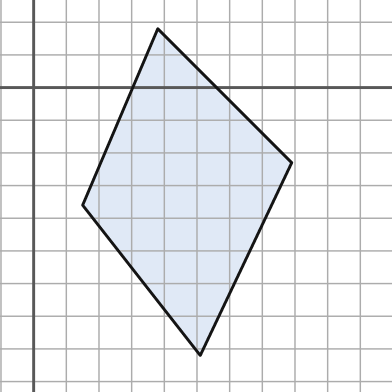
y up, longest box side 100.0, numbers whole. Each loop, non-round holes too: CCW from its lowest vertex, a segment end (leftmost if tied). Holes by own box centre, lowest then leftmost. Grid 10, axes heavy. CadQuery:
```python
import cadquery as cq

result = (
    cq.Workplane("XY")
    .moveTo(51.0, -82.0)
    .lineTo(79.0, -23.0)
    .lineTo(38.0, 18.0)
    .lineTo(15.0, -36.0)
    .close()
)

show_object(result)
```